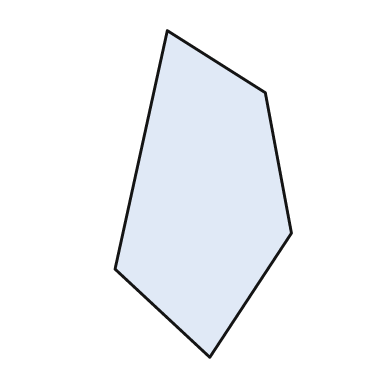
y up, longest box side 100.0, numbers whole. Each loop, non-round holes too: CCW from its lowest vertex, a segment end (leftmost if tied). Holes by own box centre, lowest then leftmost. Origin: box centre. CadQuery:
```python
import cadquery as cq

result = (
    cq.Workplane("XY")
    .moveTo(2.0, -50.0)
    .lineTo(27.0, -12.0)
    .lineTo(19.0, 31.0)
    .lineTo(-11.0, 50.0)
    .lineTo(-27.0, -23.0)
    .close()
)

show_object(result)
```